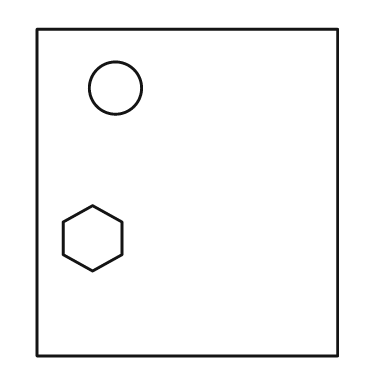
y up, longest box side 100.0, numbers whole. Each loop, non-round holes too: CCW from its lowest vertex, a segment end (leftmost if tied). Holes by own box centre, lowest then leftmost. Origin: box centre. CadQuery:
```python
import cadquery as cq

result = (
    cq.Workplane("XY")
    .moveTo(-46.0, -50.0)
    .lineTo(46.0, -50.0)
    .lineTo(46.0, 50.0)
    .lineTo(-46.0, 50.0)
    .close()
    .moveTo(-29.0, -24.0)
    .lineTo(-20.0, -19.0)
    .lineTo(-20.0, -9.0)
    .lineTo(-29.0, -4.0)
    .lineTo(-38.0, -9.0)
    .lineTo(-38.0, -19.0)
    .close()
    .moveTo(-22.0, 32.0)
    .circle(8.0)
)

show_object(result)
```